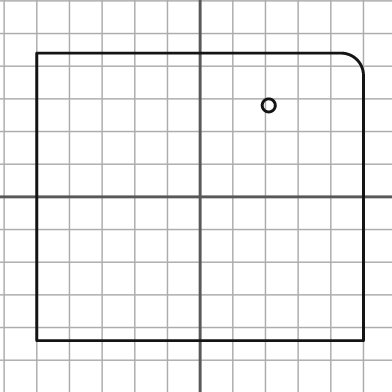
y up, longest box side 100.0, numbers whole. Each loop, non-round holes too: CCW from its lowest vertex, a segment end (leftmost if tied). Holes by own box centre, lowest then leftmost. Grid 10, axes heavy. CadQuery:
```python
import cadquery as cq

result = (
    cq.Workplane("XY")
    .moveTo(-50.0, -44.0)
    .lineTo(50.0, -44.0)
    .lineTo(50.0, 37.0)
    .threePointArc((48.0, 42.0), (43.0, 44.0))
    .lineTo(-50.0, 44.0)
    .close()
    .moveTo(21.0, 28.0)
    .circle(2.0)
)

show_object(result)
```